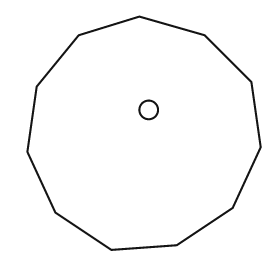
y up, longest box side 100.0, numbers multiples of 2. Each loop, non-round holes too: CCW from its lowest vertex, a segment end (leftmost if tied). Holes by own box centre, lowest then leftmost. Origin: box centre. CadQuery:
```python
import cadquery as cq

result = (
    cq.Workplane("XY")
    .moveTo(-14.0, -50.0)
    .lineTo(14.0, -48.0)
    .lineTo(38.0, -32.0)
    .lineTo(50.0, -6.0)
    .lineTo(46.0, 22.0)
    .lineTo(26.0, 42.0)
    .lineTo(-2.0, 50.0)
    .lineTo(-28.0, 42.0)
    .lineTo(-46.0, 20.0)
    .lineTo(-50.0, -8.0)
    .lineTo(-38.0, -34.0)
    .close()
    .moveTo(2.0, 10.0)
    .circle(4.0)
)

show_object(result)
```